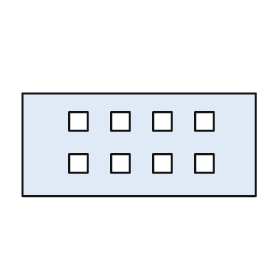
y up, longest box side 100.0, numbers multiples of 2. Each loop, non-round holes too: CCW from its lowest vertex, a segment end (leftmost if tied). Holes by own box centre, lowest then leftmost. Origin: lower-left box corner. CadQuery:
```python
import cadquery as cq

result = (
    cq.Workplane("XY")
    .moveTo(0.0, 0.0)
    .lineTo(100.0, 0.0)
    .lineTo(100.0, 44.0)
    .lineTo(0.0, 44.0)
    .close()
    .moveTo(20.0, 10.0)
    .lineTo(28.0, 10.0)
    .lineTo(28.0, 18.0)
    .lineTo(20.0, 18.0)
    .close()
    .moveTo(38.0, 10.0)
    .lineTo(46.0, 10.0)
    .lineTo(46.0, 18.0)
    .lineTo(38.0, 18.0)
    .close()
    .moveTo(56.0, 10.0)
    .lineTo(64.0, 10.0)
    .lineTo(64.0, 18.0)
    .lineTo(56.0, 18.0)
    .close()
    .moveTo(74.0, 10.0)
    .lineTo(82.0, 10.0)
    .lineTo(82.0, 18.0)
    .lineTo(74.0, 18.0)
    .close()
    .moveTo(20.0, 28.0)
    .lineTo(28.0, 28.0)
    .lineTo(28.0, 36.0)
    .lineTo(20.0, 36.0)
    .close()
    .moveTo(38.0, 28.0)
    .lineTo(46.0, 28.0)
    .lineTo(46.0, 36.0)
    .lineTo(38.0, 36.0)
    .close()
    .moveTo(56.0, 28.0)
    .lineTo(64.0, 28.0)
    .lineTo(64.0, 36.0)
    .lineTo(56.0, 36.0)
    .close()
    .moveTo(74.0, 28.0)
    .lineTo(82.0, 28.0)
    .lineTo(82.0, 36.0)
    .lineTo(74.0, 36.0)
    .close()
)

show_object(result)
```